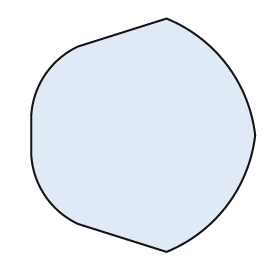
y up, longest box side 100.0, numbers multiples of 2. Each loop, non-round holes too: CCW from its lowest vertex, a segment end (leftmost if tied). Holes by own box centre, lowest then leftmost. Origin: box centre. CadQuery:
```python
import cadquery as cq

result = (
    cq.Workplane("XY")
    .moveTo(10.0, -50.0)
    .threePointArc((36.0, -30.0), (48.0, 0.0))
    .threePointArc((36.0, 30.0), (10.0, 50.0))
    .lineTo(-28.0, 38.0)
    .threePointArc((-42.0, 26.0), (-48.0, 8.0))
    .lineTo(-48.0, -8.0)
    .threePointArc((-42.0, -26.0), (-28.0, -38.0))
    .close()
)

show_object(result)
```